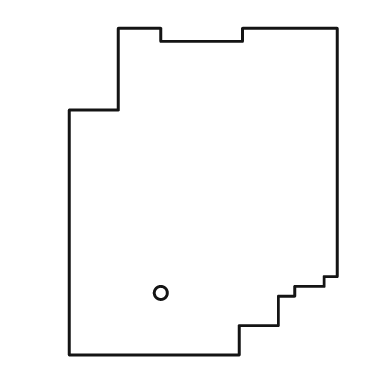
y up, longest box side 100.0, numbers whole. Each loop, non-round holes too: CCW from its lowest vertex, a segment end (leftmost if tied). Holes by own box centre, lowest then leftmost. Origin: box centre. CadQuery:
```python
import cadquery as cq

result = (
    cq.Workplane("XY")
    .moveTo(-41.0, -50.0)
    .lineTo(11.0, -50.0)
    .lineTo(11.0, -41.0)
    .lineTo(23.0, -41.0)
    .lineTo(23.0, -32.0)
    .lineTo(28.0, -32.0)
    .lineTo(28.0, -29.0)
    .lineTo(37.0, -29.0)
    .lineTo(37.0, -26.0)
    .lineTo(41.0, -26.0)
    .lineTo(41.0, 50.0)
    .lineTo(12.0, 50.0)
    .lineTo(12.0, 46.0)
    .lineTo(-13.0, 46.0)
    .lineTo(-13.0, 50.0)
    .lineTo(-26.0, 50.0)
    .lineTo(-26.0, 25.0)
    .lineTo(-41.0, 25.0)
    .close()
    .moveTo(-13.0, -31.0)
    .circle(2.0)
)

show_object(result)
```